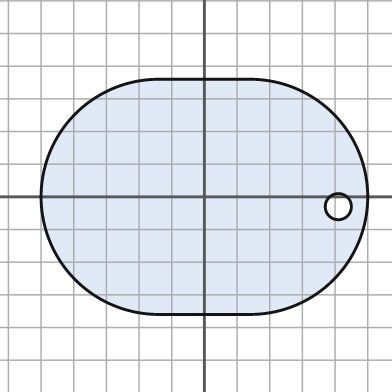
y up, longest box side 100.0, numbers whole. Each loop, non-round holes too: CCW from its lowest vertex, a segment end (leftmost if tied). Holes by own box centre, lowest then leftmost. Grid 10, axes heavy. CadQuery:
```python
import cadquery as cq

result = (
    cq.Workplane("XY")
    .moveTo(-14.0, -36.0)
    .lineTo(14.0, -36.0)
    .threePointArc((50.0, 0.0), (14.0, 36.0))
    .lineTo(-14.0, 36.0)
    .threePointArc((-50.0, 0.0), (-14.0, -36.0))
    .close()
    .moveTo(41.0, -3.0)
    .circle(4.0)
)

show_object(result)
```